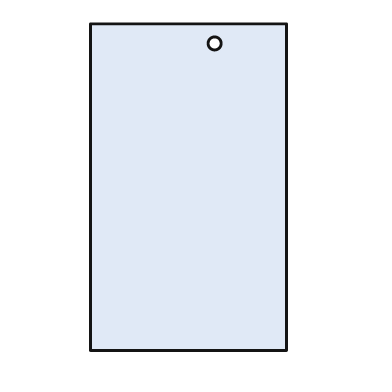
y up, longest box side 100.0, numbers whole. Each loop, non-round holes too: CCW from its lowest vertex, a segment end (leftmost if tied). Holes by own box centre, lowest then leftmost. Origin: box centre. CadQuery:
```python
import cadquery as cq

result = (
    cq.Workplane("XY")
    .moveTo(-30.0, -50.0)
    .lineTo(30.0, -50.0)
    .lineTo(30.0, 50.0)
    .lineTo(-30.0, 50.0)
    .close()
    .moveTo(8.0, 44.0)
    .circle(2.0)
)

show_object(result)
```